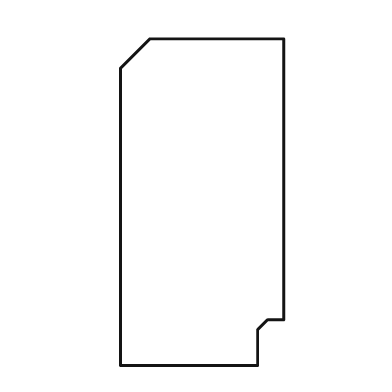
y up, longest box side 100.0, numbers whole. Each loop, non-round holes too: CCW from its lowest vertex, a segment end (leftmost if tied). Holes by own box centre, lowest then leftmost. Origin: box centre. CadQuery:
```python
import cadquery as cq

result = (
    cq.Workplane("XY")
    .moveTo(-25.0, -50.0)
    .lineTo(17.0, -50.0)
    .lineTo(17.0, -39.0)
    .lineTo(20.0, -36.0)
    .lineTo(25.0, -36.0)
    .lineTo(25.0, 50.0)
    .lineTo(-16.0, 50.0)
    .lineTo(-25.0, 41.0)
    .close()
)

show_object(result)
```